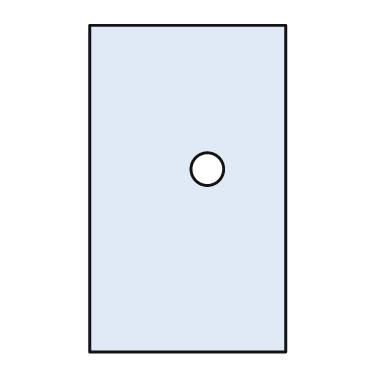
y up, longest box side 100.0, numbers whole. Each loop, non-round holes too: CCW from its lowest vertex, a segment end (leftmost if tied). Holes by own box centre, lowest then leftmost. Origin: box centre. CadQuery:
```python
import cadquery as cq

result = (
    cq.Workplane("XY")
    .moveTo(-30.0, -50.0)
    .lineTo(30.0, -50.0)
    .lineTo(30.0, 50.0)
    .lineTo(-30.0, 50.0)
    .close()
    .moveTo(6.0, 6.0)
    .circle(5.0)
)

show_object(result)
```